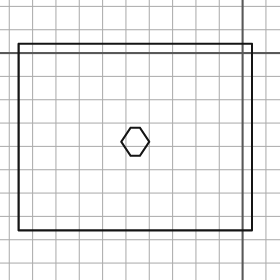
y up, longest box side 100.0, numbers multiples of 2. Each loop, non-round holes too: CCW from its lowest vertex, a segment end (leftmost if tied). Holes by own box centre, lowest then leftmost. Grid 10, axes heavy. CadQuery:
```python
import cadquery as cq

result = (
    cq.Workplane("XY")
    .moveTo(-96.0, -76.0)
    .lineTo(4.0, -76.0)
    .lineTo(4.0, 4.0)
    .lineTo(-96.0, 4.0)
    .close()
    .moveTo(-48.0, -44.0)
    .lineTo(-44.0, -44.0)
    .lineTo(-40.0, -38.0)
    .lineTo(-44.0, -32.0)
    .lineTo(-48.0, -32.0)
    .lineTo(-52.0, -38.0)
    .close()
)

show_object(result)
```